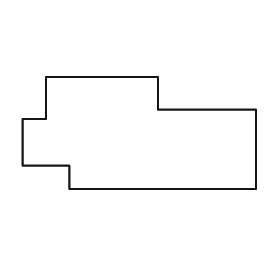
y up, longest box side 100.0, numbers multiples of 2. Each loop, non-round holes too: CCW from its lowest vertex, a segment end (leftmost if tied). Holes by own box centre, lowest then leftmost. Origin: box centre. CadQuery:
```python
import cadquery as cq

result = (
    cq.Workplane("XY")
    .moveTo(-30.0, -24.0)
    .lineTo(50.0, -24.0)
    .lineTo(50.0, 10.0)
    .lineTo(8.0, 10.0)
    .lineTo(8.0, 24.0)
    .lineTo(-40.0, 24.0)
    .lineTo(-40.0, 6.0)
    .lineTo(-50.0, 6.0)
    .lineTo(-50.0, -14.0)
    .lineTo(-30.0, -14.0)
    .close()
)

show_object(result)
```